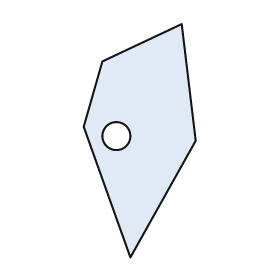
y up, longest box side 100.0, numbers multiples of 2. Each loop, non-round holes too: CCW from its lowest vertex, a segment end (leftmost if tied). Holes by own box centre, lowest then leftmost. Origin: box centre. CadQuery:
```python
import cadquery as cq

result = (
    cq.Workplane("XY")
    .moveTo(-4.0, -50.0)
    .lineTo(24.0, 0.0)
    .lineTo(18.0, 50.0)
    .lineTo(-16.0, 34.0)
    .lineTo(-24.0, 6.0)
    .close()
    .moveTo(-10.0, 2.0)
    .circle(6.0)
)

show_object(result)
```